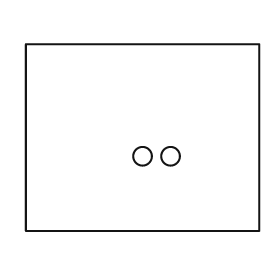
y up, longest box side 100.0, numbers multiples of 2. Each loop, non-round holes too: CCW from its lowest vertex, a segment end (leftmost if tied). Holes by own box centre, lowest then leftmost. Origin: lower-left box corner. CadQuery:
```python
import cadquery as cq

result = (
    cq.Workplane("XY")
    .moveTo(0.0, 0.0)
    .lineTo(100.0, 0.0)
    .lineTo(100.0, 80.0)
    .lineTo(0.0, 80.0)
    .close()
    .moveTo(50.0, 32.0)
    .circle(4.0)
    .moveTo(62.0, 32.0)
    .circle(4.0)
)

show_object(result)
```